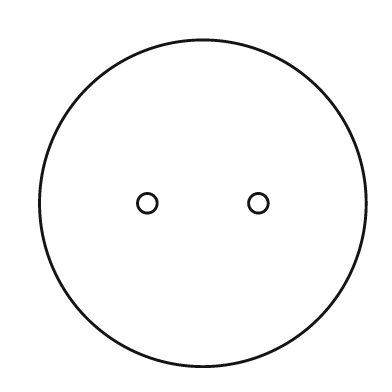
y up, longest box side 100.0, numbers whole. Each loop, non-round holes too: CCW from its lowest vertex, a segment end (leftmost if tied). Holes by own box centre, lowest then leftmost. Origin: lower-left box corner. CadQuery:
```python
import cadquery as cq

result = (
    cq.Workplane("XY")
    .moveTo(50.0, 50.0)
    .circle(50.0)
    .moveTo(33.0, 50.0)
    .circle(3.0)
    .moveTo(67.0, 50.0)
    .circle(3.0)
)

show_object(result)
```